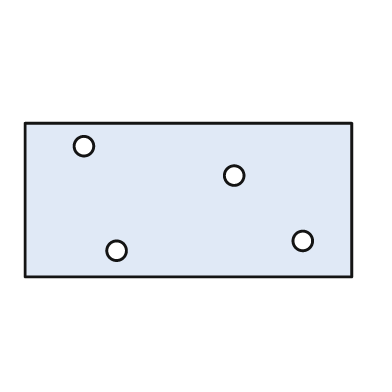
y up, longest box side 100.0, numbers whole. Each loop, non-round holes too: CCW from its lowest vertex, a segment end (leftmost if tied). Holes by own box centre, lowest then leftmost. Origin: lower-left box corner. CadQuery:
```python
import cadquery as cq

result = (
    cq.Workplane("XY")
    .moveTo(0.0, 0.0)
    .lineTo(100.0, 0.0)
    .lineTo(100.0, 47.0)
    .lineTo(0.0, 47.0)
    .close()
    .moveTo(28.0, 8.0)
    .circle(3.0)
    .moveTo(85.0, 11.0)
    .circle(3.0)
    .moveTo(64.0, 31.0)
    .circle(3.0)
    .moveTo(18.0, 40.0)
    .circle(3.0)
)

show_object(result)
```